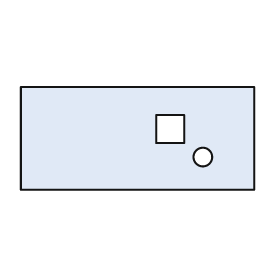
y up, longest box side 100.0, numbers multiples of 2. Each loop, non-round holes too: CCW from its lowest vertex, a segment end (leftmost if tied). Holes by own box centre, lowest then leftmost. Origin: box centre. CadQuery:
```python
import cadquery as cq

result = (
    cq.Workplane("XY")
    .moveTo(-50.0, -22.0)
    .lineTo(50.0, -22.0)
    .lineTo(50.0, 22.0)
    .lineTo(-50.0, 22.0)
    .close()
    .moveTo(28.0, -8.0)
    .circle(4.0)
    .moveTo(8.0, -2.0)
    .lineTo(20.0, -2.0)
    .lineTo(20.0, 10.0)
    .lineTo(8.0, 10.0)
    .close()
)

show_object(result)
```